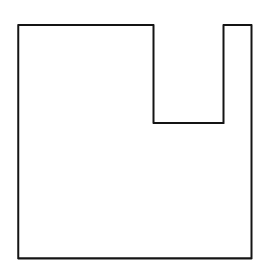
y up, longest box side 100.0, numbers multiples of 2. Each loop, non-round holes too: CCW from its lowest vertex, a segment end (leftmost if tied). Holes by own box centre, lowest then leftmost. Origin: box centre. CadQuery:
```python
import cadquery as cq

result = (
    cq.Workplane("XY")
    .moveTo(-50.0, -50.0)
    .lineTo(50.0, -50.0)
    .lineTo(50.0, 50.0)
    .lineTo(38.0, 50.0)
    .lineTo(38.0, 8.0)
    .lineTo(8.0, 8.0)
    .lineTo(8.0, 50.0)
    .lineTo(-50.0, 50.0)
    .close()
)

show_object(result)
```